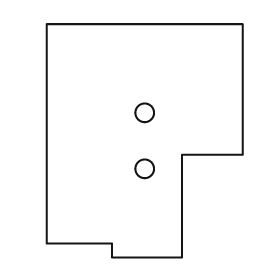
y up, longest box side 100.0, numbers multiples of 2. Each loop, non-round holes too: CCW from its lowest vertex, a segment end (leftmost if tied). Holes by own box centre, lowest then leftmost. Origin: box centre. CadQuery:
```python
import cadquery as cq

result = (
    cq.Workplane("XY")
    .moveTo(-14.0, -50.0)
    .lineTo(16.0, -50.0)
    .lineTo(16.0, -6.0)
    .lineTo(42.0, -6.0)
    .lineTo(42.0, 50.0)
    .lineTo(-42.0, 50.0)
    .lineTo(-42.0, -44.0)
    .lineTo(-14.0, -44.0)
    .close()
    .moveTo(0.0, -12.0)
    .circle(4.0)
    .moveTo(0.0, 12.0)
    .circle(4.0)
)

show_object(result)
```